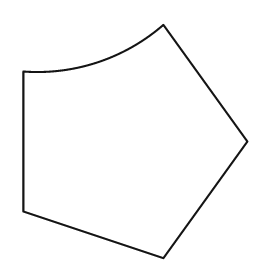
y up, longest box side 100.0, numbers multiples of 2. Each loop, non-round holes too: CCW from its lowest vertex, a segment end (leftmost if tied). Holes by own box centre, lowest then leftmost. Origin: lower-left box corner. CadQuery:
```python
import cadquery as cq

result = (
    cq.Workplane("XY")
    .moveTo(60.0, 0.0)
    .lineTo(96.0, 50.0)
    .lineTo(60.0, 100.0)
    .threePointArc((32.0, 84.0), (0.0, 80.0))
    .lineTo(0.0, 20.0)
    .close()
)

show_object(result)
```